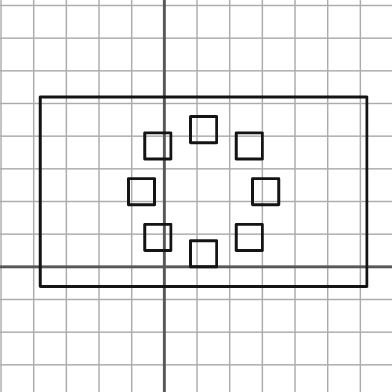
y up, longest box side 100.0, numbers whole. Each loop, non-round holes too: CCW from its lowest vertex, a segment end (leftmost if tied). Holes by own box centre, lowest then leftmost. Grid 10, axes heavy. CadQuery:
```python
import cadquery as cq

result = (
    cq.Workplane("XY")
    .moveTo(-38.0, -6.0)
    .lineTo(62.0, -6.0)
    .lineTo(62.0, 52.0)
    .lineTo(-38.0, 52.0)
    .close()
    .moveTo(8.0, 0.0)
    .lineTo(16.0, 0.0)
    .lineTo(16.0, 8.0)
    .lineTo(8.0, 8.0)
    .close()
    .moveTo(-6.0, 5.0)
    .lineTo(2.0, 5.0)
    .lineTo(2.0, 13.0)
    .lineTo(-6.0, 13.0)
    .close()
    .moveTo(22.0, 5.0)
    .lineTo(30.0, 5.0)
    .lineTo(30.0, 13.0)
    .lineTo(22.0, 13.0)
    .close()
    .moveTo(-11.0, 19.0)
    .lineTo(-3.0, 19.0)
    .lineTo(-3.0, 27.0)
    .lineTo(-11.0, 27.0)
    .close()
    .moveTo(27.0, 19.0)
    .lineTo(35.0, 19.0)
    .lineTo(35.0, 27.0)
    .lineTo(27.0, 27.0)
    .close()
    .moveTo(-6.0, 33.0)
    .lineTo(2.0, 33.0)
    .lineTo(2.0, 41.0)
    .lineTo(-6.0, 41.0)
    .close()
    .moveTo(22.0, 33.0)
    .lineTo(30.0, 33.0)
    .lineTo(30.0, 41.0)
    .lineTo(22.0, 41.0)
    .close()
    .moveTo(8.0, 38.0)
    .lineTo(16.0, 38.0)
    .lineTo(16.0, 46.0)
    .lineTo(8.0, 46.0)
    .close()
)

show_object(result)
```